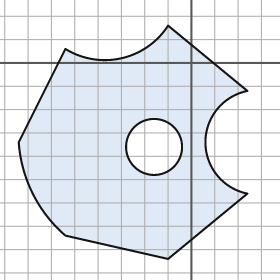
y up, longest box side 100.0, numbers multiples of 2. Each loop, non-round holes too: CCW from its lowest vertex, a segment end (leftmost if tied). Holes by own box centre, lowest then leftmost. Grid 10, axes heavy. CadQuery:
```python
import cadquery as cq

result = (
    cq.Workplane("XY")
    .moveTo(-10.0, -84.0)
    .lineTo(24.0, -56.0)
    .threePointArc((6.0, -34.0), (24.0, -12.0))
    .lineTo(-10.0, 16.0)
    .threePointArc((-30.0, 2.0), (-54.0, 6.0))
    .lineTo(-74.0, -34.0)
    .threePointArc((-68.0, -56.0), (-54.0, -74.0))
    .close()
    .moveTo(-16.0, -36.0)
    .circle(12.0)
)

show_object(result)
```